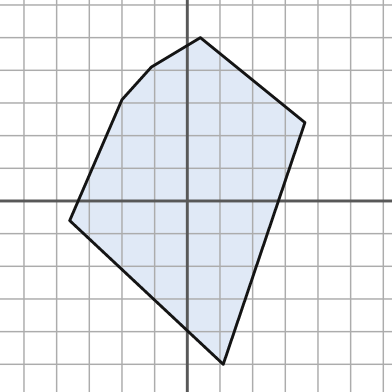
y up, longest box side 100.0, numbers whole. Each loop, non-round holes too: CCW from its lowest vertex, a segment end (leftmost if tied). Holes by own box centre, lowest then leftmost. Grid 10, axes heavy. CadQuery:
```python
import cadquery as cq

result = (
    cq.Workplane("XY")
    .moveTo(11.0, -50.0)
    .lineTo(36.0, 24.0)
    .lineTo(4.0, 50.0)
    .lineTo(-11.0, 41.0)
    .lineTo(-20.0, 31.0)
    .lineTo(-36.0, -6.0)
    .close()
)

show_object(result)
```